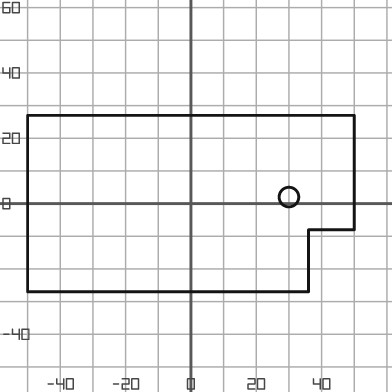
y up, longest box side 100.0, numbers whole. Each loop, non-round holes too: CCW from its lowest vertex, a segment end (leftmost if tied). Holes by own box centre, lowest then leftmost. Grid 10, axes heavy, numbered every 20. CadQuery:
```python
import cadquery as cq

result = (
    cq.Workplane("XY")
    .moveTo(-50.0, -27.0)
    .lineTo(36.0, -27.0)
    .lineTo(36.0, -8.0)
    .lineTo(50.0, -8.0)
    .lineTo(50.0, 27.0)
    .lineTo(-50.0, 27.0)
    .close()
    .moveTo(30.0, 2.0)
    .circle(3.0)
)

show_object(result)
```